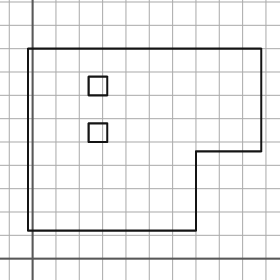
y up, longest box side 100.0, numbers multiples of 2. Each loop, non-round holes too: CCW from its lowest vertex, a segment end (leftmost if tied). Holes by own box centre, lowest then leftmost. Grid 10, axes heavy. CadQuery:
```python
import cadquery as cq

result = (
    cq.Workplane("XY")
    .moveTo(-2.0, 12.0)
    .lineTo(70.0, 12.0)
    .lineTo(70.0, 46.0)
    .lineTo(98.0, 46.0)
    .lineTo(98.0, 90.0)
    .lineTo(-2.0, 90.0)
    .close()
    .moveTo(24.0, 50.0)
    .lineTo(32.0, 50.0)
    .lineTo(32.0, 58.0)
    .lineTo(24.0, 58.0)
    .close()
    .moveTo(24.0, 70.0)
    .lineTo(32.0, 70.0)
    .lineTo(32.0, 78.0)
    .lineTo(24.0, 78.0)
    .close()
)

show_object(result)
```